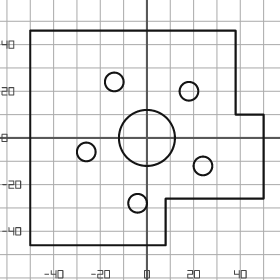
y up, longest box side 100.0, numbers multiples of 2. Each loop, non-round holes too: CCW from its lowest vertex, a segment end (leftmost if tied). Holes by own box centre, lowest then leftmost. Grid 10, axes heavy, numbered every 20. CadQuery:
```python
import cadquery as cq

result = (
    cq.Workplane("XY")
    .moveTo(-50.0, -46.0)
    .lineTo(8.0, -46.0)
    .lineTo(8.0, -26.0)
    .lineTo(50.0, -26.0)
    .lineTo(50.0, 10.0)
    .lineTo(38.0, 10.0)
    .lineTo(38.0, 46.0)
    .lineTo(-50.0, 46.0)
    .close()
    .moveTo(-4.0, -28.0)
    .circle(4.0)
    .moveTo(24.0, -12.0)
    .circle(4.0)
    .moveTo(-26.0, -6.0)
    .circle(4.0)
    .moveTo(0.0, 0.0)
    .circle(12.0)
    .moveTo(18.0, 20.0)
    .circle(4.0)
    .moveTo(-14.0, 24.0)
    .circle(4.0)
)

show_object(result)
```